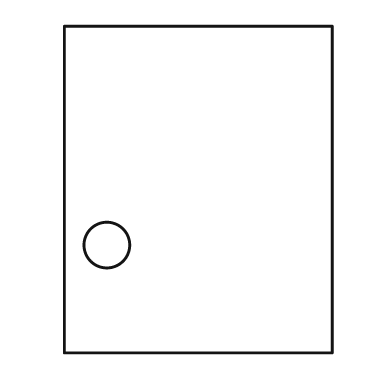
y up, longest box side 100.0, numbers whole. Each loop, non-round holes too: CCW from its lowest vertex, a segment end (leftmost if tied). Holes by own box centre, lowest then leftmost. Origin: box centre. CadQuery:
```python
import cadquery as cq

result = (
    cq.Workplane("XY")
    .moveTo(-41.0, -50.0)
    .lineTo(41.0, -50.0)
    .lineTo(41.0, 50.0)
    .lineTo(-41.0, 50.0)
    .close()
    .moveTo(-28.0, -17.0)
    .circle(7.0)
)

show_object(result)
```